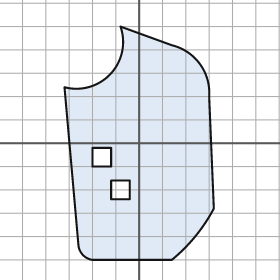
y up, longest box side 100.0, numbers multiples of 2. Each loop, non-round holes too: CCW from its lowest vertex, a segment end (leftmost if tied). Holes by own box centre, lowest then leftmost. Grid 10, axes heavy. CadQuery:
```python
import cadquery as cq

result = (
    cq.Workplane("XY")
    .moveTo(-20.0, -50.0)
    .lineTo(14.0, -50.0)
    .threePointArc((24.0, -40.0), (32.0, -28.0))
    .lineTo(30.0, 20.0)
    .threePointArc((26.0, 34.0), (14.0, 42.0))
    .lineTo(-8.0, 50.0)
    .threePointArc((-12.0, 30.0), (-32.0, 24.0))
    .lineTo(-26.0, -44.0)
    .threePointArc((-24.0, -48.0), (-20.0, -50.0))
    .close()
    .moveTo(-12.0, -24.0)
    .lineTo(-4.0, -24.0)
    .lineTo(-4.0, -16.0)
    .lineTo(-12.0, -16.0)
    .close()
    .moveTo(-20.0, -10.0)
    .lineTo(-12.0, -10.0)
    .lineTo(-12.0, -2.0)
    .lineTo(-20.0, -2.0)
    .close()
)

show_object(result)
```